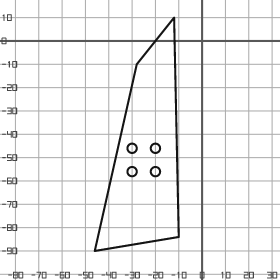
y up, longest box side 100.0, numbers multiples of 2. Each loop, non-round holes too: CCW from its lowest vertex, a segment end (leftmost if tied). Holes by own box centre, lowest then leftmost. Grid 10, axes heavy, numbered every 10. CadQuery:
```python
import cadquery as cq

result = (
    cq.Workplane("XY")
    .moveTo(-46.0, -90.0)
    .lineTo(-10.0, -84.0)
    .lineTo(-12.0, 10.0)
    .lineTo(-28.0, -10.0)
    .close()
    .moveTo(-30.0, -56.0)
    .circle(2.0)
    .moveTo(-20.0, -56.0)
    .circle(2.0)
    .moveTo(-30.0, -46.0)
    .circle(2.0)
    .moveTo(-20.0, -46.0)
    .circle(2.0)
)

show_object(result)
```